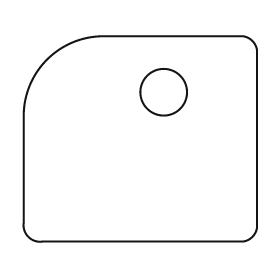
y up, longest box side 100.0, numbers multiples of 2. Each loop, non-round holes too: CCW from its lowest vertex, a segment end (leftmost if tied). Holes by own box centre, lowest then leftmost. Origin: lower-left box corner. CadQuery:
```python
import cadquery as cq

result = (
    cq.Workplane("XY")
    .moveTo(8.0, 0.0)
    .lineTo(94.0, 0.0)
    .threePointArc((98.0, 2.0), (100.0, 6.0))
    .lineTo(100.0, 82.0)
    .threePointArc((98.0, 86.0), (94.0, 88.0))
    .lineTo(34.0, 88.0)
    .threePointArc((10.0, 78.0), (0.0, 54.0))
    .lineTo(0.0, 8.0)
    .threePointArc((2.0, 2.0), (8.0, 0.0))
    .close()
    .moveTo(60.0, 64.0)
    .circle(10.0)
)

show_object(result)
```